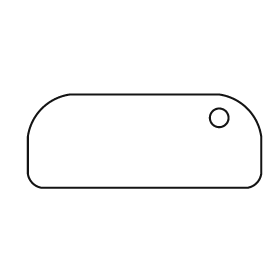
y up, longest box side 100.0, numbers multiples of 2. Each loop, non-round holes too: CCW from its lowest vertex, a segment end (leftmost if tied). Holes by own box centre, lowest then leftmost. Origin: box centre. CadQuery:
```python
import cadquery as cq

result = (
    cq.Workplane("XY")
    .moveTo(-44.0, -20.0)
    .lineTo(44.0, -20.0)
    .threePointArc((48.0, -18.0), (50.0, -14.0))
    .lineTo(50.0, 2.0)
    .threePointArc((44.0, 14.0), (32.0, 20.0))
    .lineTo(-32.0, 20.0)
    .threePointArc((-44.0, 14.0), (-50.0, 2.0))
    .lineTo(-50.0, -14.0)
    .threePointArc((-48.0, -18.0), (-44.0, -20.0))
    .close()
    .moveTo(32.0, 10.0)
    .circle(4.0)
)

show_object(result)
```